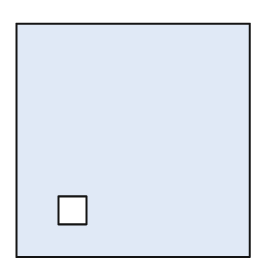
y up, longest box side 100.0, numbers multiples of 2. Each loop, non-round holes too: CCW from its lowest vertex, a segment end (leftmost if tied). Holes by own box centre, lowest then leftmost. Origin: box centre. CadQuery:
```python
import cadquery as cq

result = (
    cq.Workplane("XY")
    .moveTo(-50.0, -50.0)
    .lineTo(50.0, -50.0)
    .lineTo(50.0, 50.0)
    .lineTo(-50.0, 50.0)
    .close()
    .moveTo(-32.0, -36.0)
    .lineTo(-20.0, -36.0)
    .lineTo(-20.0, -24.0)
    .lineTo(-32.0, -24.0)
    .close()
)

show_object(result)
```